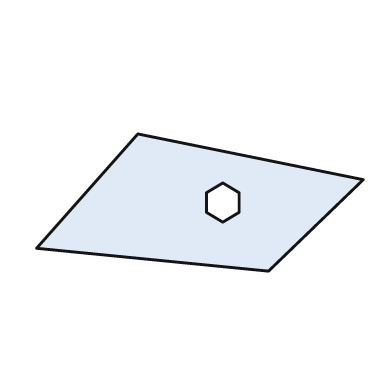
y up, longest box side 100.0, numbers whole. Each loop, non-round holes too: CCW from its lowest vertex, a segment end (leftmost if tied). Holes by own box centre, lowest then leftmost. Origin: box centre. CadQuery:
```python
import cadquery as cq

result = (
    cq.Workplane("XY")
    .moveTo(21.0, -21.0)
    .lineTo(50.0, 7.0)
    .lineTo(-19.0, 21.0)
    .lineTo(-50.0, -14.0)
    .close()
    .moveTo(7.0, -6.0)
    .lineTo(12.0, -3.0)
    .lineTo(12.0, 3.0)
    .lineTo(7.0, 6.0)
    .lineTo(2.0, 3.0)
    .lineTo(2.0, -3.0)
    .close()
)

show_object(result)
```